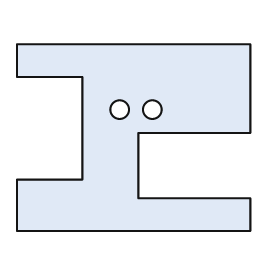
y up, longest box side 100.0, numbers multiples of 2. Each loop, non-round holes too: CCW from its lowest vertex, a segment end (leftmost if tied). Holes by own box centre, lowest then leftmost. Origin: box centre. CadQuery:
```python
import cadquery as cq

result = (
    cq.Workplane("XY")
    .moveTo(-50.0, -40.0)
    .lineTo(50.0, -40.0)
    .lineTo(50.0, -26.0)
    .lineTo(2.0, -26.0)
    .lineTo(2.0, 2.0)
    .lineTo(50.0, 2.0)
    .lineTo(50.0, 40.0)
    .lineTo(-50.0, 40.0)
    .lineTo(-50.0, 26.0)
    .lineTo(-22.0, 26.0)
    .lineTo(-22.0, -18.0)
    .lineTo(-50.0, -18.0)
    .close()
    .moveTo(-6.0, 12.0)
    .circle(4.0)
    .moveTo(8.0, 12.0)
    .circle(4.0)
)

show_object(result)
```